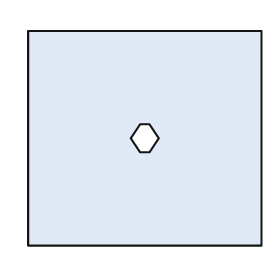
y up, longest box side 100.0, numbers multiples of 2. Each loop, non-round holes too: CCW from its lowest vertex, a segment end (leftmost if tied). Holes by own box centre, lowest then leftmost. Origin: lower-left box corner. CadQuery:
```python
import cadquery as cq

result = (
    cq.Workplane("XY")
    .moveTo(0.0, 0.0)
    .lineTo(100.0, 0.0)
    .lineTo(100.0, 92.0)
    .lineTo(0.0, 92.0)
    .close()
    .moveTo(48.0, 40.0)
    .lineTo(52.0, 40.0)
    .lineTo(56.0, 46.0)
    .lineTo(52.0, 52.0)
    .lineTo(48.0, 52.0)
    .lineTo(44.0, 46.0)
    .close()
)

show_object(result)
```